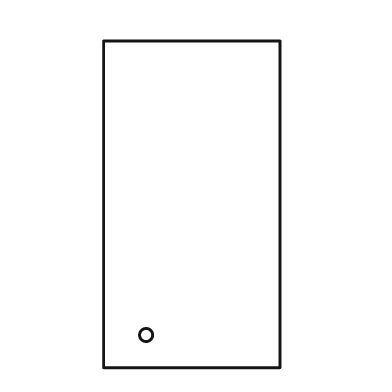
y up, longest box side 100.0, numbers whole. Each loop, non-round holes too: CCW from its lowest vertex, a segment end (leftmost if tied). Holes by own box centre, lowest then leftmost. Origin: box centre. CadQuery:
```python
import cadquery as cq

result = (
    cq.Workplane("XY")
    .moveTo(-27.0, -50.0)
    .lineTo(27.0, -50.0)
    .lineTo(27.0, 50.0)
    .lineTo(-27.0, 50.0)
    .close()
    .moveTo(-14.0, -40.0)
    .circle(2.0)
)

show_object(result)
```